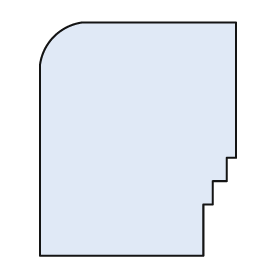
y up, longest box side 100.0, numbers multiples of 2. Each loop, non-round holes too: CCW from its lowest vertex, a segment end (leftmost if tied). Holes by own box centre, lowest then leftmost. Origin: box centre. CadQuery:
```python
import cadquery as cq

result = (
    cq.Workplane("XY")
    .moveTo(-42.0, -50.0)
    .lineTo(28.0, -50.0)
    .lineTo(28.0, -28.0)
    .lineTo(32.0, -28.0)
    .lineTo(32.0, -18.0)
    .lineTo(38.0, -18.0)
    .lineTo(38.0, -8.0)
    .lineTo(42.0, -8.0)
    .lineTo(42.0, 50.0)
    .lineTo(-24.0, 50.0)
    .threePointArc((-36.0, 44.0), (-42.0, 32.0))
    .close()
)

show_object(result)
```